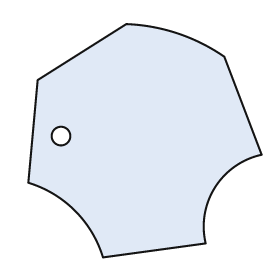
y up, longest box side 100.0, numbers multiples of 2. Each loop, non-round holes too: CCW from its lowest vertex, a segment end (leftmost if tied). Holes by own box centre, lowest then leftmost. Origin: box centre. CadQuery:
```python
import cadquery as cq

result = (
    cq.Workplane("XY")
    .moveTo(-18.0, -50.0)
    .lineTo(26.0, -44.0)
    .threePointArc((30.0, -20.0), (50.0, -6.0))
    .lineTo(34.0, 36.0)
    .threePointArc((14.0, 46.0), (-8.0, 50.0))
    .lineTo(-46.0, 26.0)
    .lineTo(-50.0, -18.0)
    .threePointArc((-30.0, -30.0), (-18.0, -50.0))
    .close()
    .moveTo(-36.0, 2.0)
    .circle(4.0)
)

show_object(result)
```